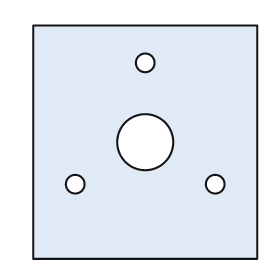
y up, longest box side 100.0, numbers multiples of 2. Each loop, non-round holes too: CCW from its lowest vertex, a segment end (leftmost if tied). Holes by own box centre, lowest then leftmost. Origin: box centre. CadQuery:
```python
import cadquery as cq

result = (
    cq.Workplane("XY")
    .moveTo(-48.0, -50.0)
    .lineTo(48.0, -50.0)
    .lineTo(48.0, 50.0)
    .lineTo(-48.0, 50.0)
    .close()
    .moveTo(-30.0, -18.0)
    .circle(4.0)
    .moveTo(30.0, -18.0)
    .circle(4.0)
    .moveTo(0.0, 0.0)
    .circle(12.0)
    .moveTo(0.0, 34.0)
    .circle(4.0)
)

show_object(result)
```